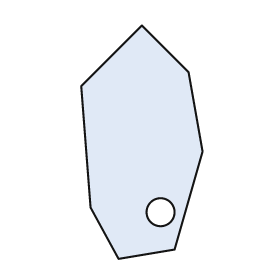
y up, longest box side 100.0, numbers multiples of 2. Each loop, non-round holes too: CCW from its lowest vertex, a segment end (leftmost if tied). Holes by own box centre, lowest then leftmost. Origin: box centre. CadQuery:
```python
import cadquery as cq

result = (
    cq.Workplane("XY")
    .moveTo(-10.0, -50.0)
    .lineTo(14.0, -46.0)
    .lineTo(26.0, -4.0)
    .lineTo(20.0, 30.0)
    .lineTo(0.0, 50.0)
    .lineTo(-26.0, 24.0)
    .lineTo(-22.0, -28.0)
    .close()
    .moveTo(8.0, -30.0)
    .circle(6.0)
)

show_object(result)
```